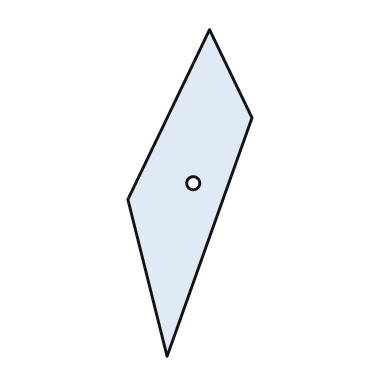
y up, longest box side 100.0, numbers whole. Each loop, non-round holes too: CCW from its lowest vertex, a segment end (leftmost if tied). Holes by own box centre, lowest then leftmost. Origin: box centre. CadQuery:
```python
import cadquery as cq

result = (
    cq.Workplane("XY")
    .moveTo(-7.0, -50.0)
    .lineTo(19.0, 23.0)
    .lineTo(6.0, 50.0)
    .lineTo(-19.0, -2.0)
    .close()
    .moveTo(1.0, 3.0)
    .circle(2.0)
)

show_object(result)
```